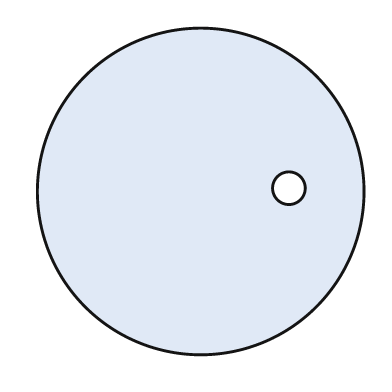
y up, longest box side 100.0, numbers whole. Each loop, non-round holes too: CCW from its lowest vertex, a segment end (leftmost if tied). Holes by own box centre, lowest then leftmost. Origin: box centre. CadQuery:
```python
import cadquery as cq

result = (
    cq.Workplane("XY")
    .moveTo(0.0, 0.0)
    .circle(50.0)
    .moveTo(27.0, 1.0)
    .circle(5.0)
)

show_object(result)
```